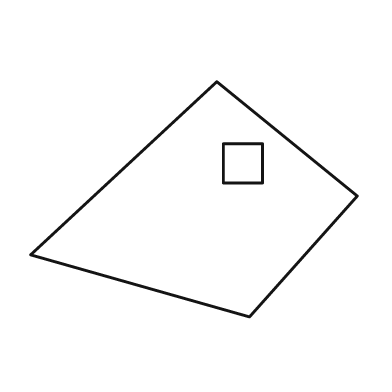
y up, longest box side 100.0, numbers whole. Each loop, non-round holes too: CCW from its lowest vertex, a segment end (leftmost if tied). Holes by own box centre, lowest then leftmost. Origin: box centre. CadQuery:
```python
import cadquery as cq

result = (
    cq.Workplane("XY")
    .moveTo(17.0, -36.0)
    .lineTo(50.0, 1.0)
    .lineTo(7.0, 36.0)
    .lineTo(-50.0, -17.0)
    .close()
    .moveTo(9.0, 5.0)
    .lineTo(21.0, 5.0)
    .lineTo(21.0, 17.0)
    .lineTo(9.0, 17.0)
    .close()
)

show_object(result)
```